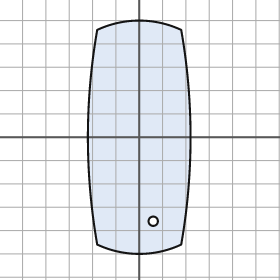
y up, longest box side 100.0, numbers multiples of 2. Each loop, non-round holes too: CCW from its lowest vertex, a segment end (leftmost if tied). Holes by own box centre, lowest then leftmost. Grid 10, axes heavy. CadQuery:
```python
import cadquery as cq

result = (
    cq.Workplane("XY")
    .moveTo(-18.0, -46.0)
    .threePointArc((0.0, -50.0), (18.0, -46.0))
    .threePointArc((22.0, 0.0), (18.0, 46.0))
    .threePointArc((0.0, 50.0), (-18.0, 46.0))
    .threePointArc((-22.0, 0.0), (-18.0, -46.0))
    .close()
    .moveTo(6.0, -36.0)
    .circle(2.0)
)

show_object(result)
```